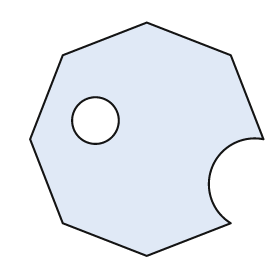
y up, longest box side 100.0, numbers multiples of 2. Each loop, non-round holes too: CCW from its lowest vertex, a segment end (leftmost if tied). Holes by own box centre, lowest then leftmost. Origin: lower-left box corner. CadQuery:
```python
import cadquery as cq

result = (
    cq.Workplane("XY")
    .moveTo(50.0, 0.0)
    .lineTo(86.0, 14.0)
    .threePointArc((78.0, 38.0), (100.0, 50.0))
    .lineTo(86.0, 86.0)
    .lineTo(50.0, 100.0)
    .lineTo(14.0, 86.0)
    .lineTo(0.0, 50.0)
    .lineTo(14.0, 14.0)
    .close()
    .moveTo(28.0, 58.0)
    .circle(10.0)
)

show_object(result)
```